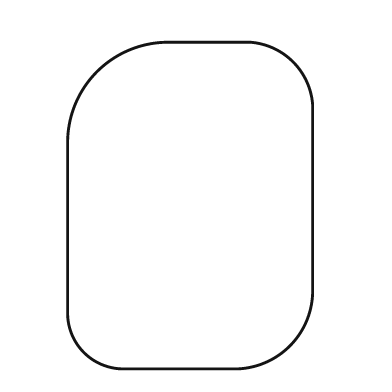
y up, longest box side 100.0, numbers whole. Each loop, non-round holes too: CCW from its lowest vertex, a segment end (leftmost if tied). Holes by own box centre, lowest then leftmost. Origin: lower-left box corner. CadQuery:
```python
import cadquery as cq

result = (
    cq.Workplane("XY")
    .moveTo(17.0, 0.0)
    .lineTo(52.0, 0.0)
    .threePointArc((68.0, 7.0), (75.0, 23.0))
    .lineTo(75.0, 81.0)
    .threePointArc((69.0, 94.0), (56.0, 100.0))
    .lineTo(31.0, 100.0)
    .threePointArc((9.0, 91.0), (0.0, 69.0))
    .lineTo(0.0, 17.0)
    .threePointArc((5.0, 5.0), (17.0, 0.0))
    .close()
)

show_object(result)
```